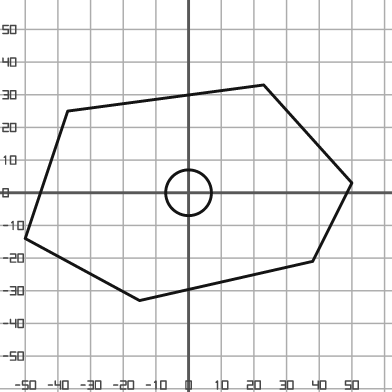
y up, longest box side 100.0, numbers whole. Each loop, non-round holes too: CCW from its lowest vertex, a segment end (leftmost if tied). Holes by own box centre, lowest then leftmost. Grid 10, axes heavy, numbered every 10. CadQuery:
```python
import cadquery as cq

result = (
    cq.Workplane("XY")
    .moveTo(-15.0, -33.0)
    .lineTo(38.0, -21.0)
    .lineTo(50.0, 3.0)
    .lineTo(23.0, 33.0)
    .lineTo(-37.0, 25.0)
    .lineTo(-50.0, -14.0)
    .close()
    .moveTo(0.0, 0.0)
    .circle(7.0)
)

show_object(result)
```